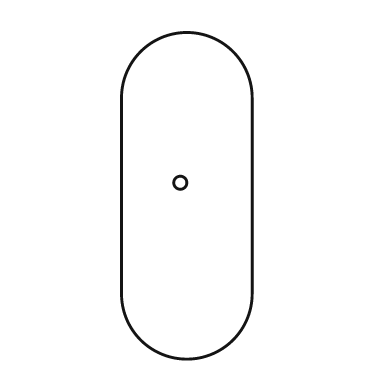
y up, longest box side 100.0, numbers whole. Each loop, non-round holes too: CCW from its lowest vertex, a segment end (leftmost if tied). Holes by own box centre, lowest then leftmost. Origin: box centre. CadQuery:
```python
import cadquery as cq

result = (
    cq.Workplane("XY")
    .moveTo(-20.0, -30.0)
    .threePointArc((0.0, -50.0), (20.0, -30.0))
    .lineTo(20.0, 30.0)
    .threePointArc((0.0, 50.0), (-20.0, 30.0))
    .close()
    .moveTo(-2.0, 4.0)
    .circle(2.0)
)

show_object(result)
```